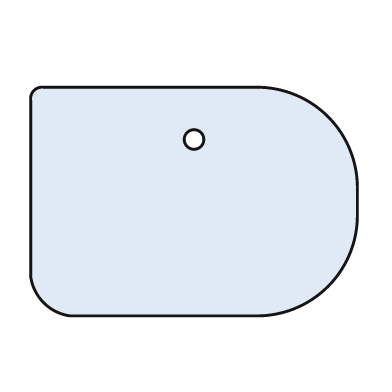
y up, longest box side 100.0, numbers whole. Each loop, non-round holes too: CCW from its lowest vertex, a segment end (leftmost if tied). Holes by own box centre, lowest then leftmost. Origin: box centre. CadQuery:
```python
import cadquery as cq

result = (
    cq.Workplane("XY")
    .moveTo(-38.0, -35.0)
    .lineTo(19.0, -35.0)
    .threePointArc((41.0, -26.0), (50.0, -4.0))
    .lineTo(50.0, 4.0)
    .threePointArc((41.0, 26.0), (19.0, 35.0))
    .lineTo(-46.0, 35.0)
    .threePointArc((-49.0, 34.0), (-50.0, 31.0))
    .lineTo(-50.0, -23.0)
    .threePointArc((-46.0, -31.0), (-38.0, -35.0))
    .close()
    .moveTo(0.0, 19.0)
    .circle(3.0)
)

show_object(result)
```